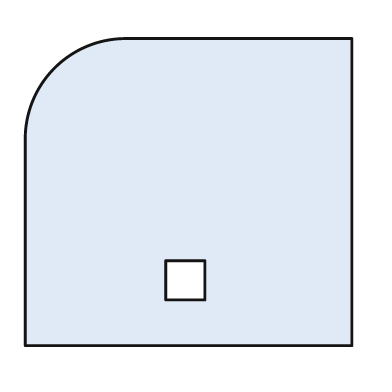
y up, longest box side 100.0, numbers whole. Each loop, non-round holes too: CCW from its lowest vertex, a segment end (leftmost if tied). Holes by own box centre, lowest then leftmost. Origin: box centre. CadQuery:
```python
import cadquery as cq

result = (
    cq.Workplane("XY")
    .moveTo(-50.0, -47.0)
    .lineTo(50.0, -47.0)
    .lineTo(50.0, 47.0)
    .lineTo(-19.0, 47.0)
    .threePointArc((-41.0, 38.0), (-50.0, 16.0))
    .close()
    .moveTo(-7.0, -33.0)
    .lineTo(5.0, -33.0)
    .lineTo(5.0, -21.0)
    .lineTo(-7.0, -21.0)
    .close()
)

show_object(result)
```